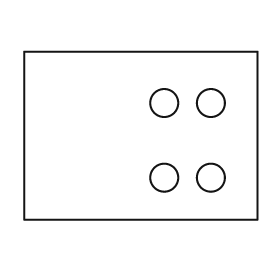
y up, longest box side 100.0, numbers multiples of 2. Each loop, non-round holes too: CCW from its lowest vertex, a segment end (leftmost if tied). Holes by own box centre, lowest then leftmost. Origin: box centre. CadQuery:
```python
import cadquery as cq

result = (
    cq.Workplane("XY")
    .moveTo(-50.0, -36.0)
    .lineTo(50.0, -36.0)
    .lineTo(50.0, 36.0)
    .lineTo(-50.0, 36.0)
    .close()
    .moveTo(10.0, -18.0)
    .circle(6.0)
    .moveTo(30.0, -18.0)
    .circle(6.0)
    .moveTo(10.0, 14.0)
    .circle(6.0)
    .moveTo(30.0, 14.0)
    .circle(6.0)
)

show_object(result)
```